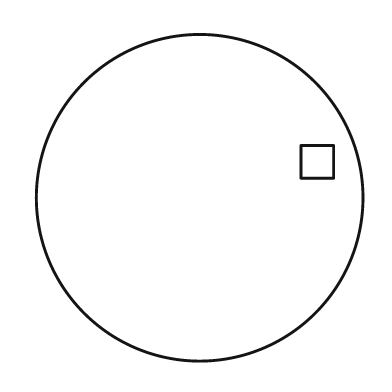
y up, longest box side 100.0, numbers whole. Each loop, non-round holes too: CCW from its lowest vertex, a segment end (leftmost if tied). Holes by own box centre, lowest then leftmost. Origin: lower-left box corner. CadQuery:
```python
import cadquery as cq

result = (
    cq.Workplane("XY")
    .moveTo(50.0, 50.0)
    .circle(50.0)
    .moveTo(81.0, 56.0)
    .lineTo(91.0, 56.0)
    .lineTo(91.0, 66.0)
    .lineTo(81.0, 66.0)
    .close()
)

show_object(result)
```